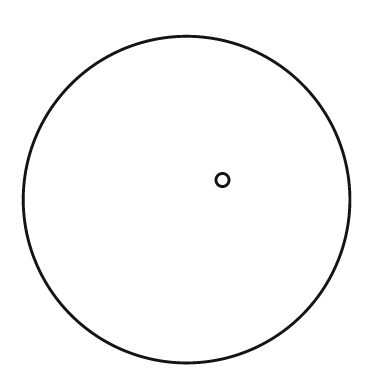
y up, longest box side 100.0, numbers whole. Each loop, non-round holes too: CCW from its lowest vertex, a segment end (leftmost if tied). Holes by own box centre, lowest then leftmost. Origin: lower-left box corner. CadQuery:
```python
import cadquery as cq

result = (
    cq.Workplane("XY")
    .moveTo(50.0, 50.0)
    .circle(50.0)
    .moveTo(61.0, 56.0)
    .circle(2.0)
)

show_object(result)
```